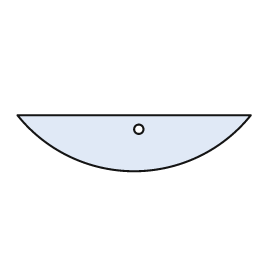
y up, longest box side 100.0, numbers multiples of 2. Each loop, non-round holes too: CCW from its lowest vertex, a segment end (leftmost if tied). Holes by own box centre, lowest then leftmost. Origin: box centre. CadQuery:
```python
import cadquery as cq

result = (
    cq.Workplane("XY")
    .moveTo(-50.0, 12.0)
    .threePointArc((0.0, -12.0), (50.0, 12.0))
    .close()
    .moveTo(2.0, 6.0)
    .circle(2.0)
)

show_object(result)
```